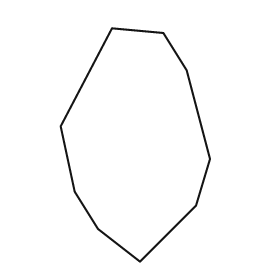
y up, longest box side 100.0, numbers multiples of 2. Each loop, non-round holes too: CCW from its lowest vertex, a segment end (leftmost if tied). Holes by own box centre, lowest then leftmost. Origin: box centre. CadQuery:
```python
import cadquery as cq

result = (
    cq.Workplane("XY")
    .moveTo(2.0, -50.0)
    .lineTo(26.0, -26.0)
    .lineTo(32.0, -6.0)
    .lineTo(22.0, 32.0)
    .lineTo(12.0, 48.0)
    .lineTo(-10.0, 50.0)
    .lineTo(-32.0, 8.0)
    .lineTo(-26.0, -20.0)
    .lineTo(-16.0, -36.0)
    .close()
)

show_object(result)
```